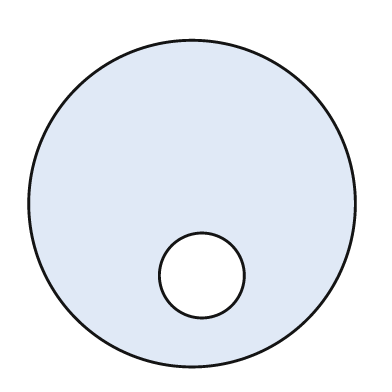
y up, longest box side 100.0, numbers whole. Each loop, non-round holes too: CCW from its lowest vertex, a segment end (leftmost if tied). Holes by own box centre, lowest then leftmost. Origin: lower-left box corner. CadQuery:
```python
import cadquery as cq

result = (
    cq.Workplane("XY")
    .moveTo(50.0, 50.0)
    .circle(50.0)
    .moveTo(53.0, 28.0)
    .circle(13.0)
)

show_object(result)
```